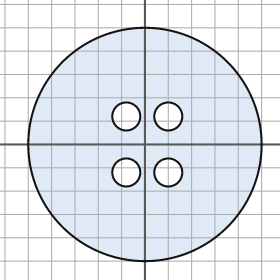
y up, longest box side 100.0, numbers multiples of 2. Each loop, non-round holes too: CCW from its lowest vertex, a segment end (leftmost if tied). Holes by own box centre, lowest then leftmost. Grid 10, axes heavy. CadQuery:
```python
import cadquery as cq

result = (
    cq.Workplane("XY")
    .moveTo(0.0, 0.0)
    .circle(50.0)
    .moveTo(-8.0, -12.0)
    .circle(6.0)
    .moveTo(10.0, -12.0)
    .circle(6.0)
    .moveTo(-8.0, 12.0)
    .circle(6.0)
    .moveTo(10.0, 12.0)
    .circle(6.0)
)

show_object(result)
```